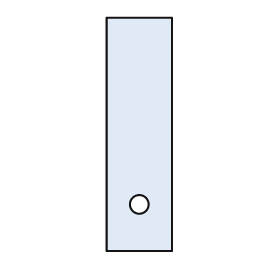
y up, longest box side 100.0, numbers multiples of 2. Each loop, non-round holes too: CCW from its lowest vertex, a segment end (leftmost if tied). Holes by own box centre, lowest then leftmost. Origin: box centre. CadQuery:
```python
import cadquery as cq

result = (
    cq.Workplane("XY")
    .moveTo(-14.0, -50.0)
    .lineTo(14.0, -50.0)
    .lineTo(14.0, 50.0)
    .lineTo(-14.0, 50.0)
    .close()
    .moveTo(0.0, -30.0)
    .circle(4.0)
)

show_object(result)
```